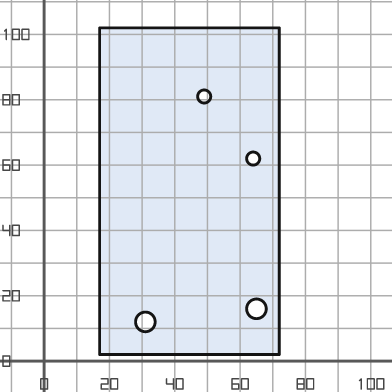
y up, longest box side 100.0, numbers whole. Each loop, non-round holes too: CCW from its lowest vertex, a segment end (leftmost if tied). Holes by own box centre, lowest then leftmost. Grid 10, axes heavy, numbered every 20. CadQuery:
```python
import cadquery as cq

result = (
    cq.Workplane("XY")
    .moveTo(17.0, 2.0)
    .lineTo(72.0, 2.0)
    .lineTo(72.0, 102.0)
    .lineTo(17.0, 102.0)
    .close()
    .moveTo(31.0, 12.0)
    .circle(3.0)
    .moveTo(65.0, 16.0)
    .circle(3.0)
    .moveTo(64.0, 62.0)
    .circle(2.0)
    .moveTo(49.0, 81.0)
    .circle(2.0)
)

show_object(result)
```